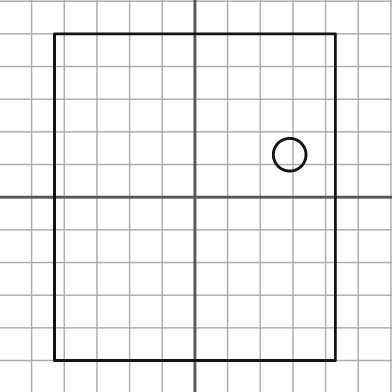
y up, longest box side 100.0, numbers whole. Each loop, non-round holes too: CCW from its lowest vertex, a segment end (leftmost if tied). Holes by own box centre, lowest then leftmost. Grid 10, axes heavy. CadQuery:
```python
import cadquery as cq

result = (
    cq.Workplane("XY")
    .moveTo(-43.0, -50.0)
    .lineTo(43.0, -50.0)
    .lineTo(43.0, 50.0)
    .lineTo(-43.0, 50.0)
    .close()
    .moveTo(29.0, 13.0)
    .circle(5.0)
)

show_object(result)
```